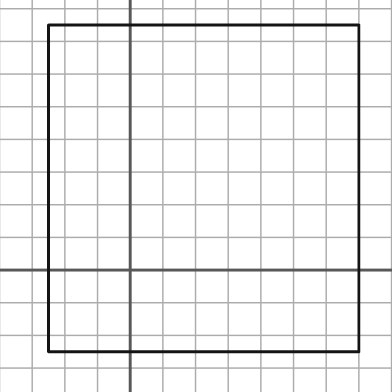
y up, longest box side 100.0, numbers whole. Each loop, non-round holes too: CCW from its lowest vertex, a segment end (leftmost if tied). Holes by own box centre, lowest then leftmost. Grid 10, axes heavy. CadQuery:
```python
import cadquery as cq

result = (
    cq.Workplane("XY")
    .moveTo(-25.0, -25.0)
    .lineTo(70.0, -25.0)
    .lineTo(70.0, 75.0)
    .lineTo(-25.0, 75.0)
    .close()
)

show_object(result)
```